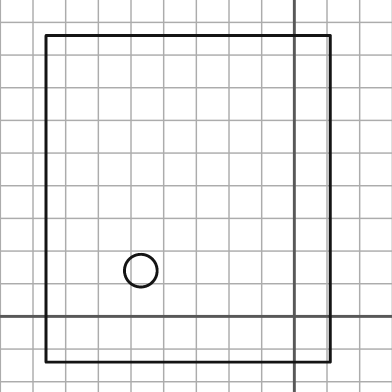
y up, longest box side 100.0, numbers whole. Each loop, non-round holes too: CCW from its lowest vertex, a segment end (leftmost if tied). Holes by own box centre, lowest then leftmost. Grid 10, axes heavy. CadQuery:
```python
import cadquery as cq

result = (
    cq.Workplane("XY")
    .moveTo(-76.0, -14.0)
    .lineTo(11.0, -14.0)
    .lineTo(11.0, 86.0)
    .lineTo(-76.0, 86.0)
    .close()
    .moveTo(-47.0, 14.0)
    .circle(5.0)
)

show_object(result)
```